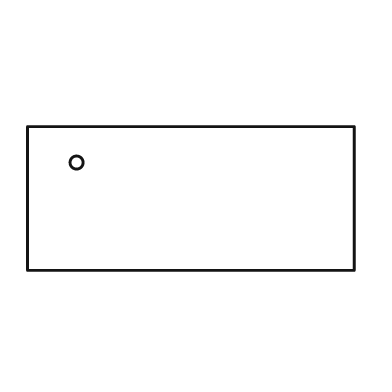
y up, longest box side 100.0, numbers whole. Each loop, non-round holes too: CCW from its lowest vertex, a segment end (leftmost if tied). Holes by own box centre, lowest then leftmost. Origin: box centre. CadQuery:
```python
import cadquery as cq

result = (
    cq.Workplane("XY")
    .moveTo(-50.0, -22.0)
    .lineTo(50.0, -22.0)
    .lineTo(50.0, 22.0)
    .lineTo(-50.0, 22.0)
    .close()
    .moveTo(-35.0, 11.0)
    .circle(2.0)
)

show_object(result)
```